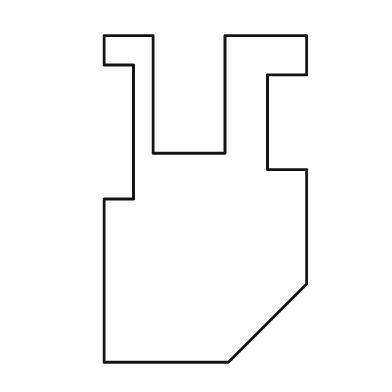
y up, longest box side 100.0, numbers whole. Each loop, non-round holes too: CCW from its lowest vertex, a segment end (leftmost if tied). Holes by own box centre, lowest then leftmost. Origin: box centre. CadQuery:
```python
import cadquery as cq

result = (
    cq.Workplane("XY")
    .moveTo(-31.0, -50.0)
    .lineTo(7.0, -50.0)
    .lineTo(31.0, -26.0)
    .lineTo(31.0, 9.0)
    .lineTo(19.0, 9.0)
    .lineTo(19.0, 38.0)
    .lineTo(31.0, 38.0)
    .lineTo(31.0, 50.0)
    .lineTo(6.0, 50.0)
    .lineTo(6.0, 14.0)
    .lineTo(-16.0, 14.0)
    .lineTo(-16.0, 50.0)
    .lineTo(-31.0, 50.0)
    .lineTo(-31.0, 41.0)
    .lineTo(-22.0, 41.0)
    .lineTo(-22.0, 0.0)
    .lineTo(-31.0, 0.0)
    .close()
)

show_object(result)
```